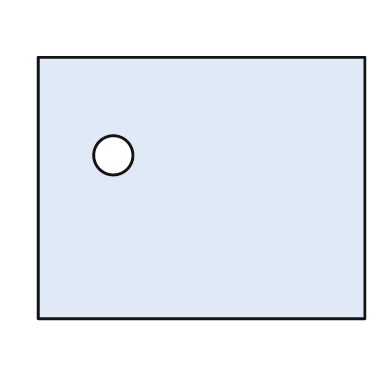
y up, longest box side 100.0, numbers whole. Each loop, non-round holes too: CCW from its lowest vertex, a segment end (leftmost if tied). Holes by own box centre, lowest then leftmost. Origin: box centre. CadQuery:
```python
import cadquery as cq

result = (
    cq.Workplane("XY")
    .moveTo(-50.0, -40.0)
    .lineTo(50.0, -40.0)
    .lineTo(50.0, 40.0)
    .lineTo(-50.0, 40.0)
    .close()
    .moveTo(-27.0, 10.0)
    .circle(6.0)
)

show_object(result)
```